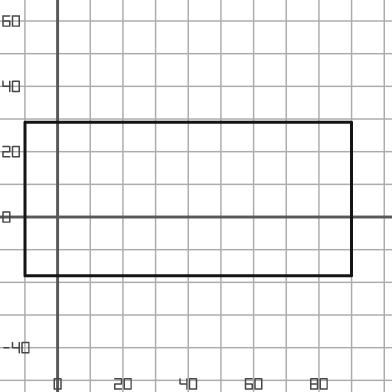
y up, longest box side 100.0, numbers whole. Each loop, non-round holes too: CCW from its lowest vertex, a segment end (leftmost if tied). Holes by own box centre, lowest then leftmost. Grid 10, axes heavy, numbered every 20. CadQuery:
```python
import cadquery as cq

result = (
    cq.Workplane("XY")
    .moveTo(-10.0, -18.0)
    .lineTo(90.0, -18.0)
    .lineTo(90.0, 29.0)
    .lineTo(-10.0, 29.0)
    .close()
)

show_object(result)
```